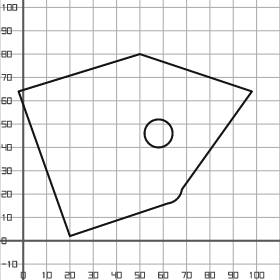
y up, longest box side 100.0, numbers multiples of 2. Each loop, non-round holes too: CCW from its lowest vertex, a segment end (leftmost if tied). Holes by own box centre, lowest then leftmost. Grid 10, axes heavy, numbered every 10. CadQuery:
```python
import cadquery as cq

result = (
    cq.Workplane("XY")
    .moveTo(20.0, 2.0)
    .lineTo(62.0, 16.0)
    .threePointArc((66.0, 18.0), (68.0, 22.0))
    .lineTo(98.0, 64.0)
    .lineTo(50.0, 80.0)
    .lineTo(-2.0, 64.0)
    .close()
    .moveTo(58.0, 46.0)
    .circle(6.0)
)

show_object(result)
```